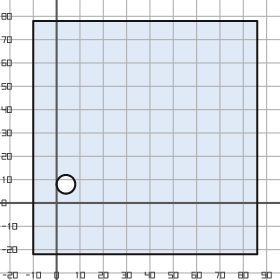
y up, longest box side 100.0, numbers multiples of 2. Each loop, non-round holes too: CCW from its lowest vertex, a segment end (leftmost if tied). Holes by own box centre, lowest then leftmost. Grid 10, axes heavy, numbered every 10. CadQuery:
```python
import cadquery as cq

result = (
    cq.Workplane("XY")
    .moveTo(-10.0, -22.0)
    .lineTo(86.0, -22.0)
    .lineTo(86.0, 78.0)
    .lineTo(-10.0, 78.0)
    .close()
    .moveTo(4.0, 8.0)
    .circle(4.0)
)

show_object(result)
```